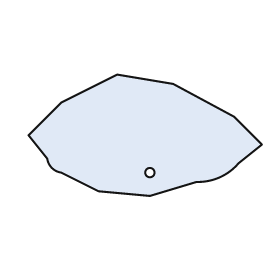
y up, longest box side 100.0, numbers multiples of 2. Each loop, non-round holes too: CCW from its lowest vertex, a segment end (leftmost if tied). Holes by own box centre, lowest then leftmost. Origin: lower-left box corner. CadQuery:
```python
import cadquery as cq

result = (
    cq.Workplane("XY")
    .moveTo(52.0, 0.0)
    .lineTo(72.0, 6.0)
    .threePointArc((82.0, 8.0), (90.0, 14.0))
    .lineTo(100.0, 22.0)
    .lineTo(88.0, 34.0)
    .lineTo(62.0, 48.0)
    .lineTo(38.0, 52.0)
    .lineTo(14.0, 40.0)
    .lineTo(0.0, 26.0)
    .lineTo(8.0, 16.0)
    .threePointArc((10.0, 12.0), (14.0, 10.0))
    .lineTo(30.0, 2.0)
    .close()
    .moveTo(52.0, 10.0)
    .circle(2.0)
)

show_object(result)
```